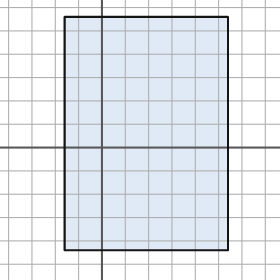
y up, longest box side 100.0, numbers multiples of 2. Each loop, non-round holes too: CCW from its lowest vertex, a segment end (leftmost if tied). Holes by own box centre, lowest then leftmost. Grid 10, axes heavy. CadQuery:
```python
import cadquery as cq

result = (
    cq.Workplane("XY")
    .moveTo(-16.0, -44.0)
    .lineTo(54.0, -44.0)
    .lineTo(54.0, 56.0)
    .lineTo(-16.0, 56.0)
    .close()
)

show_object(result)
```